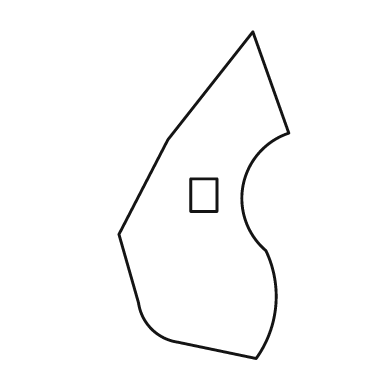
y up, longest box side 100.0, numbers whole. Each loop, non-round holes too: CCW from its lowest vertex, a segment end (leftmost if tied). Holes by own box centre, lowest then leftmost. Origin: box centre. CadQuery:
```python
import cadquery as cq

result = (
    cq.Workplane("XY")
    .moveTo(16.0, -50.0)
    .threePointArc((22.0, -34.0), (19.0, -17.0))
    .threePointArc((12.0, 3.0), (26.0, 19.0))
    .lineTo(15.0, 50.0)
    .lineTo(-11.0, 17.0)
    .lineTo(-26.0, -12.0)
    .lineTo(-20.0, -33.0)
    .threePointArc((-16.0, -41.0), (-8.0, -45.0))
    .close()
    .moveTo(-4.0, -5.0)
    .lineTo(4.0, -5.0)
    .lineTo(4.0, 5.0)
    .lineTo(-4.0, 5.0)
    .close()
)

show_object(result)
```